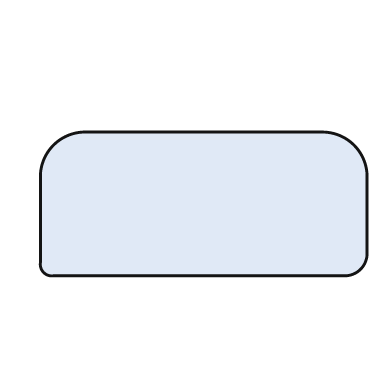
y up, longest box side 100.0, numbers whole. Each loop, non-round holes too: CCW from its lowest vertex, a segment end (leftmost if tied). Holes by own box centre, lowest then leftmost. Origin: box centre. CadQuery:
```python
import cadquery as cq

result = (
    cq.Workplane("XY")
    .moveTo(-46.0, -22.0)
    .lineTo(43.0, -22.0)
    .threePointArc((48.0, -20.0), (50.0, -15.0))
    .lineTo(50.0, 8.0)
    .threePointArc((46.0, 18.0), (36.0, 22.0))
    .lineTo(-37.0, 22.0)
    .threePointArc((-46.0, 18.0), (-50.0, 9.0))
    .lineTo(-50.0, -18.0)
    .threePointArc((-49.0, -21.0), (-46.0, -22.0))
    .close()
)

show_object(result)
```